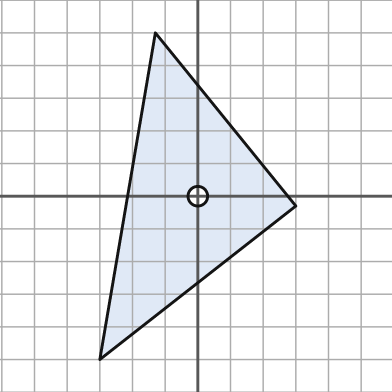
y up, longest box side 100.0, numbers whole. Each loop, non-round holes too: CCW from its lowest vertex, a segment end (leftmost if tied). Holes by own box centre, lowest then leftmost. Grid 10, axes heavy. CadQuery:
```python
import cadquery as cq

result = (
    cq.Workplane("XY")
    .moveTo(-30.0, -50.0)
    .lineTo(30.0, -3.0)
    .lineTo(-13.0, 50.0)
    .close()
    .moveTo(0.0, 0.0)
    .circle(3.0)
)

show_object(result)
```